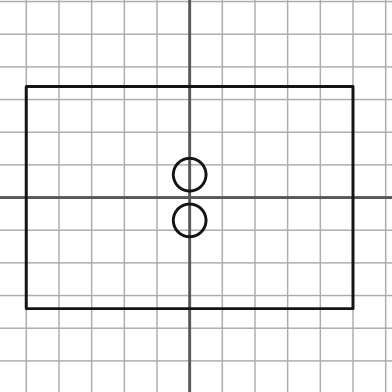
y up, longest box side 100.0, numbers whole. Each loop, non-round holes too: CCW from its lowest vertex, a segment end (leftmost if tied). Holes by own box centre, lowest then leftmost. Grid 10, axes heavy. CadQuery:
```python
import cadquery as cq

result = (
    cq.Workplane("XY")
    .moveTo(-50.0, -34.0)
    .lineTo(50.0, -34.0)
    .lineTo(50.0, 34.0)
    .lineTo(-50.0, 34.0)
    .close()
    .moveTo(0.0, -7.0)
    .circle(5.0)
    .moveTo(0.0, 7.0)
    .circle(5.0)
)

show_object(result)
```